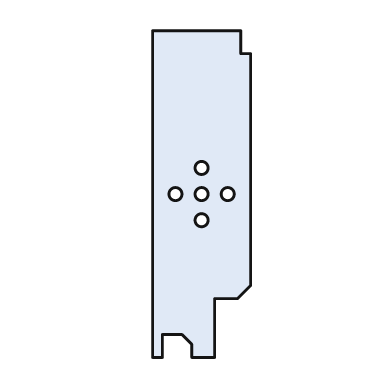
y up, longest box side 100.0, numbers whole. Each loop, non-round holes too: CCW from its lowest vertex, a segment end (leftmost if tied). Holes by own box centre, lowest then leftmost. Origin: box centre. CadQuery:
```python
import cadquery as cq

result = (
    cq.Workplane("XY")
    .moveTo(-15.0, -50.0)
    .lineTo(-12.0, -50.0)
    .lineTo(-12.0, -43.0)
    .lineTo(-6.0, -43.0)
    .lineTo(-3.0, -46.0)
    .lineTo(-3.0, -50.0)
    .lineTo(4.0, -50.0)
    .lineTo(4.0, -32.0)
    .lineTo(11.0, -32.0)
    .lineTo(15.0, -28.0)
    .lineTo(15.0, 43.0)
    .lineTo(12.0, 43.0)
    .lineTo(12.0, 50.0)
    .lineTo(-15.0, 50.0)
    .close()
    .moveTo(0.0, -8.0)
    .circle(2.0)
    .moveTo(-8.0, 0.0)
    .circle(2.0)
    .moveTo(0.0, 0.0)
    .circle(2.0)
    .moveTo(8.0, 0.0)
    .circle(2.0)
    .moveTo(0.0, 8.0)
    .circle(2.0)
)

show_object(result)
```